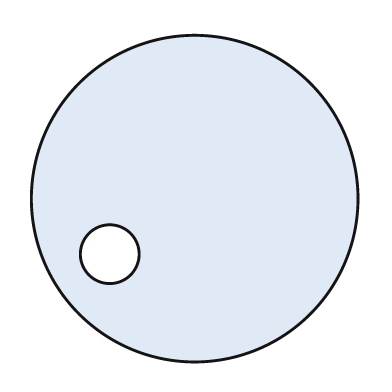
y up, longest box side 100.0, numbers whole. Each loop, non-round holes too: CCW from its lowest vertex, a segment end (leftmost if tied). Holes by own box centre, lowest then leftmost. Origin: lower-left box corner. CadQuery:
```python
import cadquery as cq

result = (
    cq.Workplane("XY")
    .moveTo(50.0, 50.0)
    .circle(50.0)
    .moveTo(24.0, 33.0)
    .circle(9.0)
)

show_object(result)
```